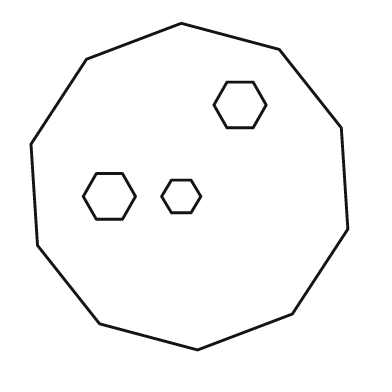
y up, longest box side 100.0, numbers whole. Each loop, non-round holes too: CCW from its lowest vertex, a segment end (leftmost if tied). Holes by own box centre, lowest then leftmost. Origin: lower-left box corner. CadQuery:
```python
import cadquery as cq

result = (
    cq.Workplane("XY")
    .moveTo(51.0, 0.0)
    .lineTo(80.0, 11.0)
    .lineTo(97.0, 37.0)
    .lineTo(95.0, 68.0)
    .lineTo(76.0, 92.0)
    .lineTo(46.0, 100.0)
    .lineTo(17.0, 89.0)
    .lineTo(0.0, 63.0)
    .lineTo(2.0, 32.0)
    .lineTo(21.0, 8.0)
    .close()
    .moveTo(20.0, 40.0)
    .lineTo(28.0, 40.0)
    .lineTo(32.0, 47.0)
    .lineTo(28.0, 54.0)
    .lineTo(20.0, 54.0)
    .lineTo(16.0, 47.0)
    .close()
    .moveTo(43.0, 42.0)
    .lineTo(49.0, 42.0)
    .lineTo(52.0, 47.0)
    .lineTo(49.0, 52.0)
    .lineTo(43.0, 52.0)
    .lineTo(40.0, 47.0)
    .close()
    .moveTo(60.0, 68.0)
    .lineTo(68.0, 68.0)
    .lineTo(72.0, 75.0)
    .lineTo(68.0, 82.0)
    .lineTo(60.0, 82.0)
    .lineTo(56.0, 75.0)
    .close()
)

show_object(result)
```